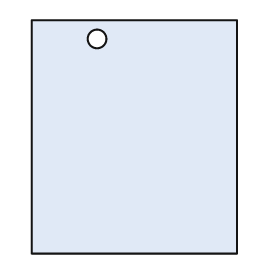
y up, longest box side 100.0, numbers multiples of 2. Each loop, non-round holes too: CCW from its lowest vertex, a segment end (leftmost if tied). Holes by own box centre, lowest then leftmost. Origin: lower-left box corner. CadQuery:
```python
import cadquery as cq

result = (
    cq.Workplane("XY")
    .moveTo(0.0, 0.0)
    .lineTo(88.0, 0.0)
    .lineTo(88.0, 100.0)
    .lineTo(0.0, 100.0)
    .close()
    .moveTo(28.0, 92.0)
    .circle(4.0)
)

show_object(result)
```